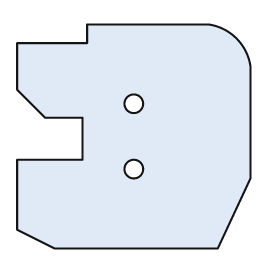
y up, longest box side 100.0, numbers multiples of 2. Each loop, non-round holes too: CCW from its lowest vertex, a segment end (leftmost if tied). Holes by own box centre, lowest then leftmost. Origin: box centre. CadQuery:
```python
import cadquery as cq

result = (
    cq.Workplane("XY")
    .moveTo(-34.0, -48.0)
    .lineTo(36.0, -48.0)
    .lineTo(50.0, -18.0)
    .lineTo(50.0, 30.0)
    .threePointArc((44.0, 42.0), (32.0, 48.0))
    .lineTo(-20.0, 48.0)
    .lineTo(-20.0, 40.0)
    .lineTo(-50.0, 40.0)
    .lineTo(-50.0, 20.0)
    .lineTo(-38.0, 8.0)
    .lineTo(-22.0, 8.0)
    .lineTo(-22.0, -10.0)
    .lineTo(-50.0, -10.0)
    .lineTo(-50.0, -40.0)
    .close()
    .moveTo(0.0, -14.0)
    .circle(4.0)
    .moveTo(0.0, 14.0)
    .circle(4.0)
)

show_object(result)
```